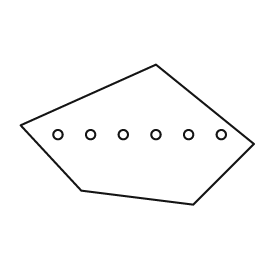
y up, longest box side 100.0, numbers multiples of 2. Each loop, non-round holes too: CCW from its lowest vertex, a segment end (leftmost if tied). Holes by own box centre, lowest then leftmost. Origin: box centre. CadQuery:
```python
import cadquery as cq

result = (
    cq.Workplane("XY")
    .moveTo(24.0, -30.0)
    .lineTo(50.0, -4.0)
    .lineTo(8.0, 30.0)
    .lineTo(-50.0, 4.0)
    .lineTo(-24.0, -24.0)
    .close()
    .moveTo(-34.0, 0.0)
    .circle(2.0)
    .moveTo(-20.0, 0.0)
    .circle(2.0)
    .moveTo(-6.0, 0.0)
    .circle(2.0)
    .moveTo(8.0, 0.0)
    .circle(2.0)
    .moveTo(22.0, 0.0)
    .circle(2.0)
    .moveTo(36.0, 0.0)
    .circle(2.0)
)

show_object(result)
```